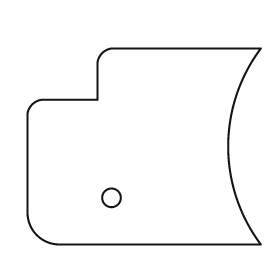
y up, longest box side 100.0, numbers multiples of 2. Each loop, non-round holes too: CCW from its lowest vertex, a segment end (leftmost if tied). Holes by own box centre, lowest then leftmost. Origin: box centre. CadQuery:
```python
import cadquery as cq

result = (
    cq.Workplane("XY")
    .moveTo(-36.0, -42.0)
    .lineTo(50.0, -42.0)
    .threePointArc((36.0, 0.0), (50.0, 42.0))
    .lineTo(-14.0, 42.0)
    .threePointArc((-18.0, 40.0), (-20.0, 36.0))
    .lineTo(-20.0, 20.0)
    .lineTo(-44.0, 20.0)
    .threePointArc((-48.0, 18.0), (-50.0, 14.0))
    .lineTo(-50.0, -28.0)
    .threePointArc((-46.0, -38.0), (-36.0, -42.0))
    .close()
    .moveTo(-14.0, -22.0)
    .circle(4.0)
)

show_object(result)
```